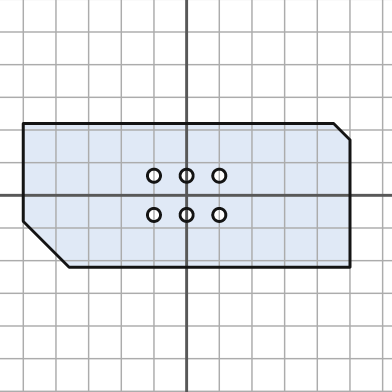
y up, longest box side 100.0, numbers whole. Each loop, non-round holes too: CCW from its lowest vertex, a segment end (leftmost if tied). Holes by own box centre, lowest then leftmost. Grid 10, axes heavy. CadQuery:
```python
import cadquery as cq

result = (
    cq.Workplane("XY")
    .moveTo(-36.0, -22.0)
    .lineTo(50.0, -22.0)
    .lineTo(50.0, 17.0)
    .lineTo(45.0, 22.0)
    .lineTo(-50.0, 22.0)
    .lineTo(-50.0, -8.0)
    .close()
    .moveTo(-10.0, -6.0)
    .circle(2.0)
    .moveTo(0.0, -6.0)
    .circle(2.0)
    .moveTo(10.0, -6.0)
    .circle(2.0)
    .moveTo(-10.0, 6.0)
    .circle(2.0)
    .moveTo(0.0, 6.0)
    .circle(2.0)
    .moveTo(10.0, 6.0)
    .circle(2.0)
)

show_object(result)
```